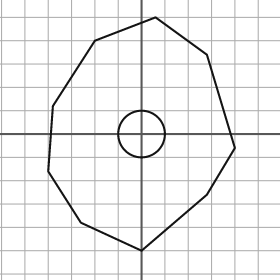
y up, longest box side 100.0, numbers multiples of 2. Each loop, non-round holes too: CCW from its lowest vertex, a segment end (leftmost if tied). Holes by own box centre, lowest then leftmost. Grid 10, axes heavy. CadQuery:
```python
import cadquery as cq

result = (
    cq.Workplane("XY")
    .moveTo(0.0, -50.0)
    .lineTo(28.0, -26.0)
    .lineTo(40.0, -6.0)
    .lineTo(28.0, 34.0)
    .lineTo(6.0, 50.0)
    .lineTo(-20.0, 40.0)
    .lineTo(-38.0, 12.0)
    .lineTo(-40.0, -16.0)
    .lineTo(-26.0, -38.0)
    .close()
    .moveTo(0.0, 0.0)
    .circle(10.0)
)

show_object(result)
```